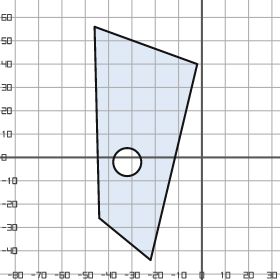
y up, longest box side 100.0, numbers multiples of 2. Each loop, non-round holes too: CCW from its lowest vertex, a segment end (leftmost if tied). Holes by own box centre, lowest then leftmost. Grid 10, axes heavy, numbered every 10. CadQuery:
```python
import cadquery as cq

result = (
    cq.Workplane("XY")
    .moveTo(-22.0, -44.0)
    .lineTo(-2.0, 40.0)
    .lineTo(-46.0, 56.0)
    .lineTo(-44.0, -26.0)
    .close()
    .moveTo(-32.0, -2.0)
    .circle(6.0)
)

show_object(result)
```